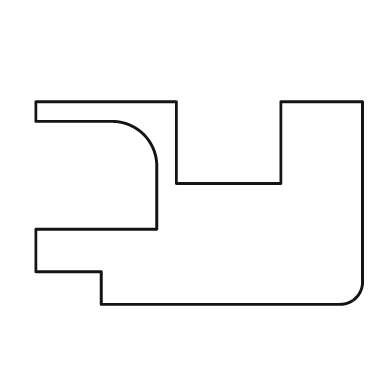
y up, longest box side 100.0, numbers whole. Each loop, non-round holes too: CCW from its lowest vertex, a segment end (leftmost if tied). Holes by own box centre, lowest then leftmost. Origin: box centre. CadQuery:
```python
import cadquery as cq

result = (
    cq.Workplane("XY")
    .moveTo(-30.0, -31.0)
    .lineTo(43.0, -31.0)
    .threePointArc((48.0, -29.0), (50.0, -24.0))
    .lineTo(50.0, 31.0)
    .lineTo(25.0, 31.0)
    .lineTo(25.0, 6.0)
    .lineTo(-7.0, 6.0)
    .lineTo(-7.0, 31.0)
    .lineTo(-50.0, 31.0)
    .lineTo(-50.0, 25.0)
    .lineTo(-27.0, 25.0)
    .threePointArc((-17.0, 21.0), (-13.0, 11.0))
    .lineTo(-13.0, -8.0)
    .lineTo(-50.0, -8.0)
    .lineTo(-50.0, -21.0)
    .lineTo(-30.0, -21.0)
    .close()
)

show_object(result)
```